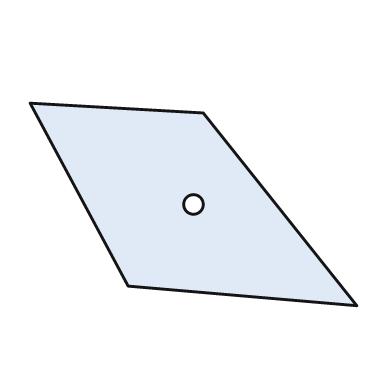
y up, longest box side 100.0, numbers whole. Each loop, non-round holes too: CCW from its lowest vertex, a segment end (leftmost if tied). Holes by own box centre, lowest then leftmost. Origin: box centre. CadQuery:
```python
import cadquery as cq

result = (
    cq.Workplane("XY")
    .moveTo(50.0, -31.0)
    .lineTo(3.0, 28.0)
    .lineTo(-50.0, 31.0)
    .lineTo(-20.0, -25.0)
    .close()
    .moveTo(0.0, 0.0)
    .circle(3.0)
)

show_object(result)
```